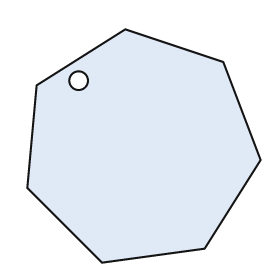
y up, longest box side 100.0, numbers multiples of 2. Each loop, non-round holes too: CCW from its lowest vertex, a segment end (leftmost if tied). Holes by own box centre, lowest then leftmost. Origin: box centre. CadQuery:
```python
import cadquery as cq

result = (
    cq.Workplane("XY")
    .moveTo(-18.0, -50.0)
    .lineTo(26.0, -44.0)
    .lineTo(50.0, -6.0)
    .lineTo(34.0, 36.0)
    .lineTo(-8.0, 50.0)
    .lineTo(-46.0, 26.0)
    .lineTo(-50.0, -18.0)
    .close()
    .moveTo(-28.0, 28.0)
    .circle(4.0)
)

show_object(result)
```